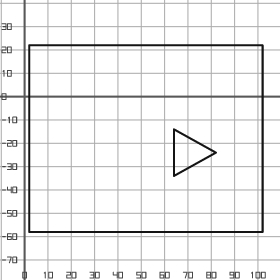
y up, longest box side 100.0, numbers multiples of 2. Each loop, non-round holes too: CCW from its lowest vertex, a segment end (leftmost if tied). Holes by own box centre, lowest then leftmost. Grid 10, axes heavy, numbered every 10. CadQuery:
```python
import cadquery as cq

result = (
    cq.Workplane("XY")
    .moveTo(2.0, -58.0)
    .lineTo(102.0, -58.0)
    .lineTo(102.0, 22.0)
    .lineTo(2.0, 22.0)
    .close()
    .moveTo(64.0, -34.0)
    .lineTo(82.0, -24.0)
    .lineTo(64.0, -14.0)
    .close()
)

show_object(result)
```